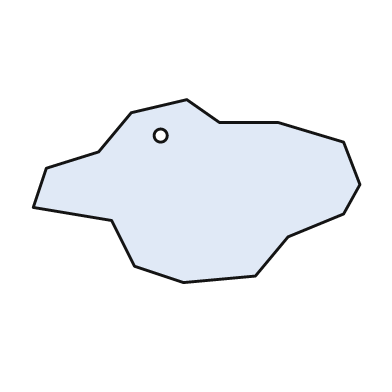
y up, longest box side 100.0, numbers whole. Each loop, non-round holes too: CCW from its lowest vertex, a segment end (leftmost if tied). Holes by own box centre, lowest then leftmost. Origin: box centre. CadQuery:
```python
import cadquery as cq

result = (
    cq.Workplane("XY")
    .moveTo(-4.0, -28.0)
    .lineTo(18.0, -26.0)
    .lineTo(28.0, -14.0)
    .lineTo(45.0, -7.0)
    .lineTo(50.0, 2.0)
    .lineTo(45.0, 15.0)
    .lineTo(25.0, 21.0)
    .lineTo(7.0, 21.0)
    .lineTo(-3.0, 28.0)
    .lineTo(-20.0, 24.0)
    .lineTo(-30.0, 12.0)
    .lineTo(-46.0, 7.0)
    .lineTo(-50.0, -5.0)
    .lineTo(-26.0, -9.0)
    .lineTo(-19.0, -23.0)
    .close()
    .moveTo(-11.0, 17.0)
    .circle(2.0)
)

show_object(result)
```